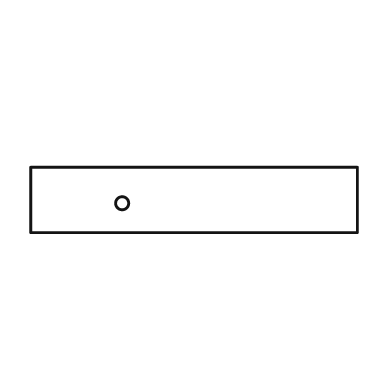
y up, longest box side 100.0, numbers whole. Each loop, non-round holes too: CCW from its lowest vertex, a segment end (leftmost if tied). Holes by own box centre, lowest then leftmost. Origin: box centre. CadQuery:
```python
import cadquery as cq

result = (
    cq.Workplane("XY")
    .moveTo(-50.0, -10.0)
    .lineTo(50.0, -10.0)
    .lineTo(50.0, 10.0)
    .lineTo(-50.0, 10.0)
    .close()
    .moveTo(-22.0, -1.0)
    .circle(2.0)
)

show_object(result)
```